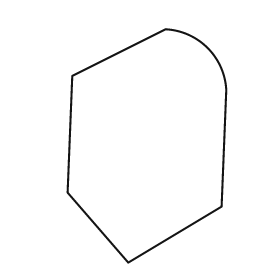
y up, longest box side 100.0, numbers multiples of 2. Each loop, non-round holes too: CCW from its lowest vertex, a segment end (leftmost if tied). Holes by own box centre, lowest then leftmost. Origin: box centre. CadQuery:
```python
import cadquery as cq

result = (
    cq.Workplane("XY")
    .moveTo(-8.0, -50.0)
    .lineTo(32.0, -26.0)
    .lineTo(34.0, 24.0)
    .threePointArc((26.0, 42.0), (8.0, 50.0))
    .lineTo(-32.0, 30.0)
    .lineTo(-34.0, -20.0)
    .close()
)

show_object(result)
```